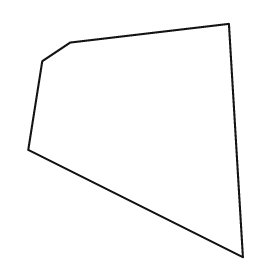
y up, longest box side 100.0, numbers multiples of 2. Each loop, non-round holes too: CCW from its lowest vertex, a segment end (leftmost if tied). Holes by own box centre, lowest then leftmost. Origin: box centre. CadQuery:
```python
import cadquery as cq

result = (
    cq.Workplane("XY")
    .moveTo(46.0, -50.0)
    .lineTo(40.0, 50.0)
    .lineTo(-28.0, 42.0)
    .lineTo(-40.0, 34.0)
    .lineTo(-46.0, -4.0)
    .close()
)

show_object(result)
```